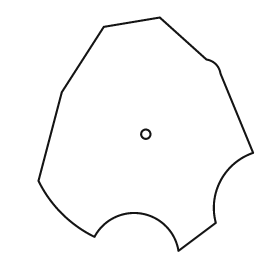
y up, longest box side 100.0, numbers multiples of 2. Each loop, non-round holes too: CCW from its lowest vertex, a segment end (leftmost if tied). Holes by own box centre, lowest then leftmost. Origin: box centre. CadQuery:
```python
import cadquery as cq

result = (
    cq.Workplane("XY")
    .moveTo(14.0, -50.0)
    .lineTo(30.0, -38.0)
    .threePointArc((32.0, -20.0), (46.0, -8.0))
    .lineTo(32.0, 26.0)
    .threePointArc((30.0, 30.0), (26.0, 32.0))
    .lineTo(6.0, 50.0)
    .lineTo(-18.0, 46.0)
    .lineTo(-36.0, 18.0)
    .lineTo(-46.0, -20.0)
    .threePointArc((-36.0, -34.0), (-22.0, -44.0))
    .threePointArc((-2.0, -34.0), (14.0, -50.0))
    .close()
    .moveTo(0.0, 0.0)
    .circle(2.0)
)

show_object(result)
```